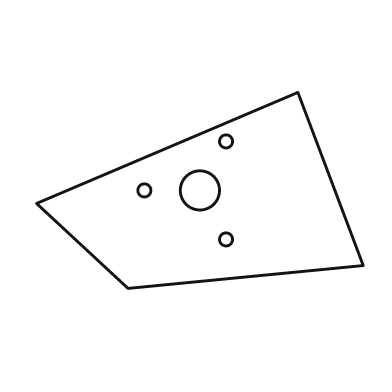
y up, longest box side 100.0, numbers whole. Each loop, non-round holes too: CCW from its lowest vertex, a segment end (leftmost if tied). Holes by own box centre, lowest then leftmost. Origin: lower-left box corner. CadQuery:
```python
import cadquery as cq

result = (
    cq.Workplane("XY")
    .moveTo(28.0, 0.0)
    .lineTo(100.0, 7.0)
    .lineTo(80.0, 60.0)
    .lineTo(0.0, 26.0)
    .close()
    .moveTo(58.0, 15.0)
    .circle(2.0)
    .moveTo(33.0, 30.0)
    .circle(2.0)
    .moveTo(50.0, 30.0)
    .circle(6.0)
    .moveTo(58.0, 45.0)
    .circle(2.0)
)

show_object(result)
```